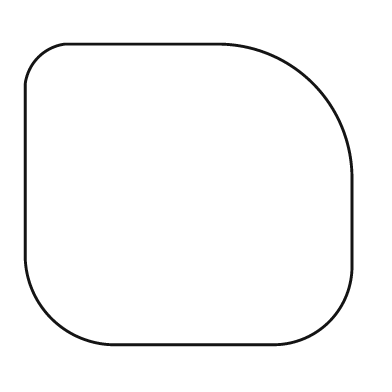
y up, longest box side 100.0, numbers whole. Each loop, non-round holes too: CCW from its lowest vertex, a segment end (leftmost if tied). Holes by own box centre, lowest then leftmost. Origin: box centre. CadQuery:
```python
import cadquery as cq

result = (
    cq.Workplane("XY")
    .moveTo(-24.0, -46.0)
    .lineTo(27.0, -46.0)
    .threePointArc((43.0, -39.0), (50.0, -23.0))
    .lineTo(50.0, 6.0)
    .threePointArc((38.0, 34.0), (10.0, 46.0))
    .lineTo(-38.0, 46.0)
    .threePointArc((-46.0, 42.0), (-50.0, 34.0))
    .lineTo(-50.0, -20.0)
    .threePointArc((-42.0, -38.0), (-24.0, -46.0))
    .close()
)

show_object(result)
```